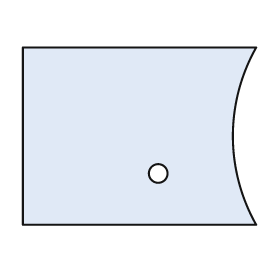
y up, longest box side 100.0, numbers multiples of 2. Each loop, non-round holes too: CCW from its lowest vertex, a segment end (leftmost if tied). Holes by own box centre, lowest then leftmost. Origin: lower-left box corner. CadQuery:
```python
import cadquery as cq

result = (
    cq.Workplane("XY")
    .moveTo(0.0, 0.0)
    .lineTo(100.0, 0.0)
    .threePointArc((90.0, 38.0), (100.0, 76.0))
    .lineTo(0.0, 76.0)
    .close()
    .moveTo(58.0, 22.0)
    .circle(4.0)
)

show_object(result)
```